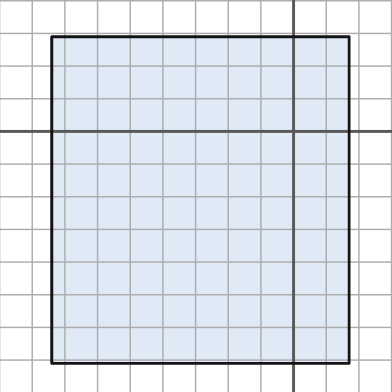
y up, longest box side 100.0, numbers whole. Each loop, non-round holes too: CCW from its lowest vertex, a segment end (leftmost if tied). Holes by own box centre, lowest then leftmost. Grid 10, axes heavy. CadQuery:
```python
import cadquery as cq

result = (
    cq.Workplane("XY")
    .moveTo(-74.0, -71.0)
    .lineTo(17.0, -71.0)
    .lineTo(17.0, 29.0)
    .lineTo(-74.0, 29.0)
    .close()
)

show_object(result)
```